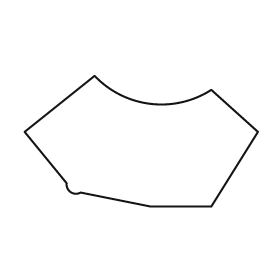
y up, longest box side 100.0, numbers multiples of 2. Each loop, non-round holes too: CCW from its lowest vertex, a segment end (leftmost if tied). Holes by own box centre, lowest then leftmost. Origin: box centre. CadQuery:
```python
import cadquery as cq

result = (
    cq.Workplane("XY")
    .moveTo(4.0, -28.0)
    .lineTo(30.0, -28.0)
    .lineTo(50.0, 4.0)
    .lineTo(30.0, 22.0)
    .threePointArc((4.0, 16.0), (-20.0, 28.0))
    .lineTo(-50.0, 4.0)
    .lineTo(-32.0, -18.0)
    .threePointArc((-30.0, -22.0), (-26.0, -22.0))
    .close()
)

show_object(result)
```